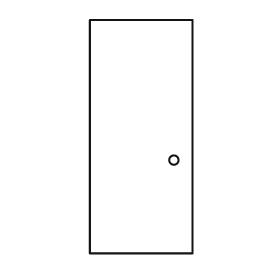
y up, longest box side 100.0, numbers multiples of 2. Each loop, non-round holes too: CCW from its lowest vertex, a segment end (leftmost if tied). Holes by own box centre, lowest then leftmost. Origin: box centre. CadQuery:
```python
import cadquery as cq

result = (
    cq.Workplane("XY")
    .moveTo(-22.0, -50.0)
    .lineTo(22.0, -50.0)
    .lineTo(22.0, 50.0)
    .lineTo(-22.0, 50.0)
    .close()
    .moveTo(14.0, -10.0)
    .circle(2.0)
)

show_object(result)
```